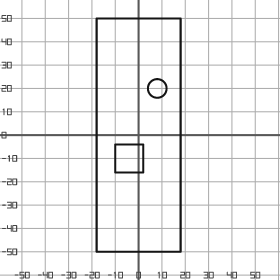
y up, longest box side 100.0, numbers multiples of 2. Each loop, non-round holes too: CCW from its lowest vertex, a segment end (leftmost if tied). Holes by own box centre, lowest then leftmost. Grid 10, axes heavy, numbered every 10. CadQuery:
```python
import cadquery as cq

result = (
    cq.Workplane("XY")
    .moveTo(-18.0, -50.0)
    .lineTo(18.0, -50.0)
    .lineTo(18.0, 50.0)
    .lineTo(-18.0, 50.0)
    .close()
    .moveTo(-10.0, -16.0)
    .lineTo(2.0, -16.0)
    .lineTo(2.0, -4.0)
    .lineTo(-10.0, -4.0)
    .close()
    .moveTo(8.0, 20.0)
    .circle(4.0)
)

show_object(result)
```